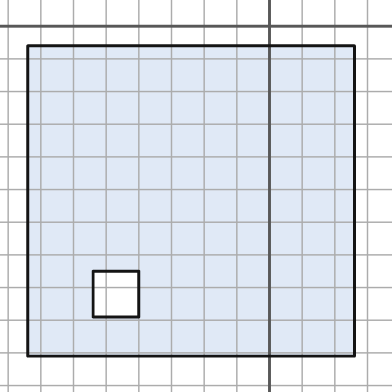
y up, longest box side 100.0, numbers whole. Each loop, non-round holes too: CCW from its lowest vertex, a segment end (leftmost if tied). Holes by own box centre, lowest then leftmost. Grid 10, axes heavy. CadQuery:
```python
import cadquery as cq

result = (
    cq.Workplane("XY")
    .moveTo(-74.0, -101.0)
    .lineTo(26.0, -101.0)
    .lineTo(26.0, -6.0)
    .lineTo(-74.0, -6.0)
    .close()
    .moveTo(-54.0, -89.0)
    .lineTo(-40.0, -89.0)
    .lineTo(-40.0, -75.0)
    .lineTo(-54.0, -75.0)
    .close()
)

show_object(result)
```